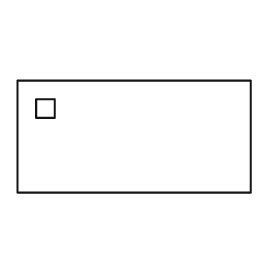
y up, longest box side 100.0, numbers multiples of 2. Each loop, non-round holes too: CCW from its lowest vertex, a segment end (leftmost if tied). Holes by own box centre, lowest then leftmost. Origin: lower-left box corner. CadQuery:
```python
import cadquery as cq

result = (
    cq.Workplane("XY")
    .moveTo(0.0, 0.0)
    .lineTo(100.0, 0.0)
    .lineTo(100.0, 48.0)
    .lineTo(0.0, 48.0)
    .close()
    .moveTo(8.0, 32.0)
    .lineTo(16.0, 32.0)
    .lineTo(16.0, 40.0)
    .lineTo(8.0, 40.0)
    .close()
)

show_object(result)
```